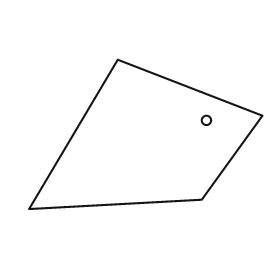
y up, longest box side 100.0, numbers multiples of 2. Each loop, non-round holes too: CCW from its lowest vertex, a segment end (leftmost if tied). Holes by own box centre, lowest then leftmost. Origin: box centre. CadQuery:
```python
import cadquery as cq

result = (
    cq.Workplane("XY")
    .moveTo(-50.0, -32.0)
    .lineTo(24.0, -28.0)
    .lineTo(50.0, 8.0)
    .lineTo(-12.0, 32.0)
    .close()
    .moveTo(26.0, 6.0)
    .circle(2.0)
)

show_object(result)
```